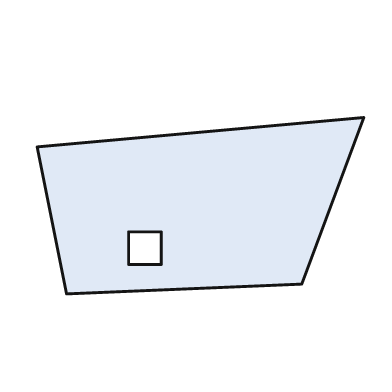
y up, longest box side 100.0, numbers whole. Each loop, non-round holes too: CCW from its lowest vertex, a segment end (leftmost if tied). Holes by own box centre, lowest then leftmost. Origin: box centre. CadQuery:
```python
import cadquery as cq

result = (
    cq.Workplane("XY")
    .moveTo(-41.0, -27.0)
    .lineTo(31.0, -24.0)
    .lineTo(50.0, 27.0)
    .lineTo(-50.0, 18.0)
    .close()
    .moveTo(-22.0, -18.0)
    .lineTo(-12.0, -18.0)
    .lineTo(-12.0, -8.0)
    .lineTo(-22.0, -8.0)
    .close()
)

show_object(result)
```